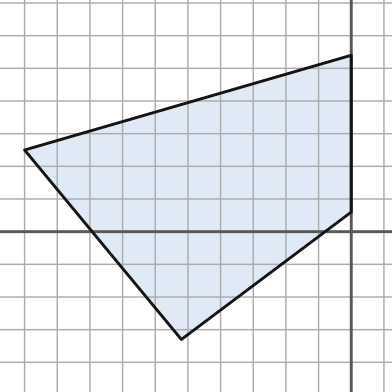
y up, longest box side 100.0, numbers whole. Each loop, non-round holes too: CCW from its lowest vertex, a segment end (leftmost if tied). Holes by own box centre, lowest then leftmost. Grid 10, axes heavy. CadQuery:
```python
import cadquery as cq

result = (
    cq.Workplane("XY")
    .moveTo(-52.0, -33.0)
    .lineTo(0.0, 6.0)
    .lineTo(0.0, 54.0)
    .lineTo(-100.0, 25.0)
    .close()
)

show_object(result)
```